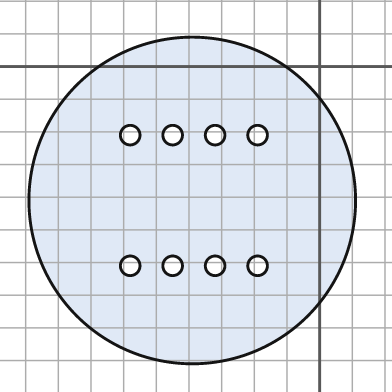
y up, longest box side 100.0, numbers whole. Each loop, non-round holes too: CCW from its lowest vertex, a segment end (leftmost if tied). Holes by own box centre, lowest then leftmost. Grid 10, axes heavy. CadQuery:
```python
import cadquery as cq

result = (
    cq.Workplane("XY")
    .moveTo(-39.0, -41.0)
    .circle(50.0)
    .moveTo(-58.0, -61.0)
    .circle(3.0)
    .moveTo(-45.0, -61.0)
    .circle(3.0)
    .moveTo(-32.0, -61.0)
    .circle(3.0)
    .moveTo(-19.0, -61.0)
    .circle(3.0)
    .moveTo(-58.0, -21.0)
    .circle(3.0)
    .moveTo(-45.0, -21.0)
    .circle(3.0)
    .moveTo(-32.0, -21.0)
    .circle(3.0)
    .moveTo(-19.0, -21.0)
    .circle(3.0)
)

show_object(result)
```